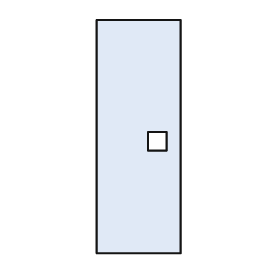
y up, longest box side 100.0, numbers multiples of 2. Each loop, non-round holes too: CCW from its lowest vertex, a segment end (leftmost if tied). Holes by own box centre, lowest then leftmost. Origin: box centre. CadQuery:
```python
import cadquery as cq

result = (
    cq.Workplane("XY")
    .moveTo(-18.0, -50.0)
    .lineTo(18.0, -50.0)
    .lineTo(18.0, 50.0)
    .lineTo(-18.0, 50.0)
    .close()
    .moveTo(4.0, -6.0)
    .lineTo(12.0, -6.0)
    .lineTo(12.0, 2.0)
    .lineTo(4.0, 2.0)
    .close()
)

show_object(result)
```